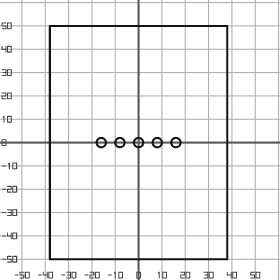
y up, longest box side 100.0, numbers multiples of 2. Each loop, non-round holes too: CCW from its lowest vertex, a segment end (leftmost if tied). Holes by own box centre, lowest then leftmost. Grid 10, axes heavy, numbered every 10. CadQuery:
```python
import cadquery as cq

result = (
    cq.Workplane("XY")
    .moveTo(-38.0, -50.0)
    .lineTo(38.0, -50.0)
    .lineTo(38.0, 50.0)
    .lineTo(-38.0, 50.0)
    .close()
    .moveTo(-16.0, 0.0)
    .circle(2.0)
    .moveTo(-8.0, 0.0)
    .circle(2.0)
    .moveTo(0.0, 0.0)
    .circle(2.0)
    .moveTo(8.0, 0.0)
    .circle(2.0)
    .moveTo(16.0, 0.0)
    .circle(2.0)
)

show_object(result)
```